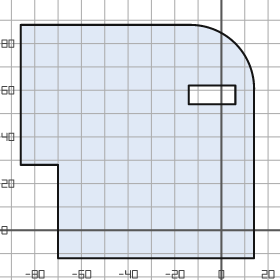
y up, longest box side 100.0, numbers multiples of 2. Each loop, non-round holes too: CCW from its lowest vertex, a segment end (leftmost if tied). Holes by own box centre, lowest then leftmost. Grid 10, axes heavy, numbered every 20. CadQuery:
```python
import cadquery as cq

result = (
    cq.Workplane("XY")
    .moveTo(-70.0, -12.0)
    .lineTo(14.0, -12.0)
    .lineTo(14.0, 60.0)
    .threePointArc((6.0, 80.0), (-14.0, 88.0))
    .lineTo(-86.0, 88.0)
    .lineTo(-86.0, 28.0)
    .lineTo(-70.0, 28.0)
    .close()
    .moveTo(-14.0, 54.0)
    .lineTo(6.0, 54.0)
    .lineTo(6.0, 62.0)
    .lineTo(-14.0, 62.0)
    .close()
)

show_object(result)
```